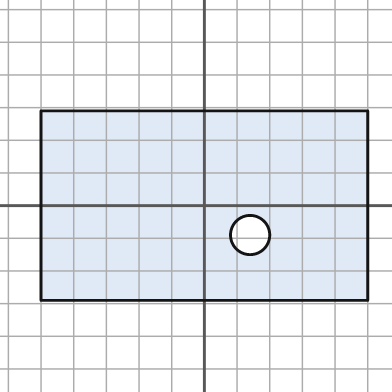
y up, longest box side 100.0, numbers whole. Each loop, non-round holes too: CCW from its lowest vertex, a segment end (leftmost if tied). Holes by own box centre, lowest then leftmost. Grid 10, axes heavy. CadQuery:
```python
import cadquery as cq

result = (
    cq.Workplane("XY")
    .moveTo(-50.0, -29.0)
    .lineTo(50.0, -29.0)
    .lineTo(50.0, 29.0)
    .lineTo(-50.0, 29.0)
    .close()
    .moveTo(14.0, -9.0)
    .circle(6.0)
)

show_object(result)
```